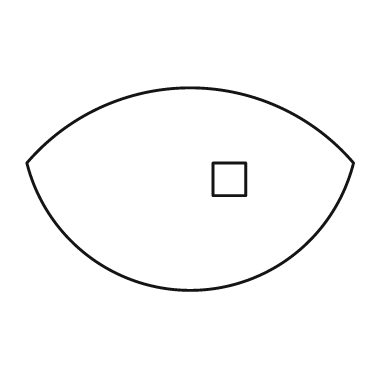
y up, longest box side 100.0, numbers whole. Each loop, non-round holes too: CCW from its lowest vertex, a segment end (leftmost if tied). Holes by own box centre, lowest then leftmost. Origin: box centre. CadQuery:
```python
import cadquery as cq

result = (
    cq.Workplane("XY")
    .moveTo(-50.0, 8.0)
    .threePointArc((0.0, -31.0), (50.0, 8.0))
    .threePointArc((0.0, 31.0), (-50.0, 8.0))
    .close()
    .moveTo(7.0, -2.0)
    .lineTo(17.0, -2.0)
    .lineTo(17.0, 8.0)
    .lineTo(7.0, 8.0)
    .close()
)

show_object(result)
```